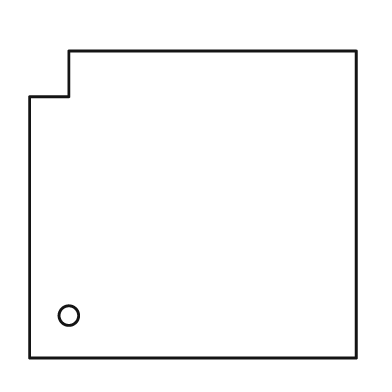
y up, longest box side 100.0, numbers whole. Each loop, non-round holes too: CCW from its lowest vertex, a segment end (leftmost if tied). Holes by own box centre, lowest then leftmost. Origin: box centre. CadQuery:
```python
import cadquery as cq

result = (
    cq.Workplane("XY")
    .moveTo(-50.0, -47.0)
    .lineTo(50.0, -47.0)
    .lineTo(50.0, 47.0)
    .lineTo(-38.0, 47.0)
    .lineTo(-38.0, 33.0)
    .lineTo(-50.0, 33.0)
    .close()
    .moveTo(-38.0, -34.0)
    .circle(3.0)
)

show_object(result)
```